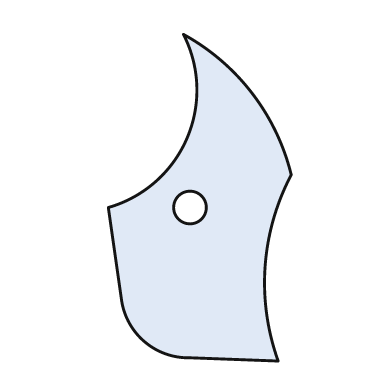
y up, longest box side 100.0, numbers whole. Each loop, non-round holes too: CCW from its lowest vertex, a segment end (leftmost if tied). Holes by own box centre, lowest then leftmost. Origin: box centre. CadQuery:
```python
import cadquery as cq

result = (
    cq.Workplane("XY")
    .moveTo(24.0, -50.0)
    .threePointArc((20.0, -21.0), (28.0, 7.0))
    .threePointArc((16.0, 32.0), (-5.0, 50.0))
    .threePointArc((-4.0, 18.0), (-28.0, -3.0))
    .lineTo(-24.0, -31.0)
    .threePointArc((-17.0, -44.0), (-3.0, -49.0))
    .close()
    .moveTo(-3.0, -3.0)
    .circle(5.0)
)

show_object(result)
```